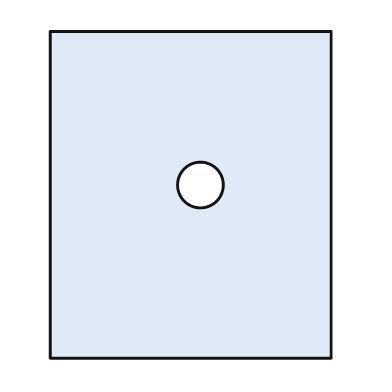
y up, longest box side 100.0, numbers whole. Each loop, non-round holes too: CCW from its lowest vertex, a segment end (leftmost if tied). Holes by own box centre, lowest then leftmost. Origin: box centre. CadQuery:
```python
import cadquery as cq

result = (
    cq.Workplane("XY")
    .moveTo(-43.0, -50.0)
    .lineTo(43.0, -50.0)
    .lineTo(43.0, 50.0)
    .lineTo(-43.0, 50.0)
    .close()
    .moveTo(3.0, 3.0)
    .circle(7.0)
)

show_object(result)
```